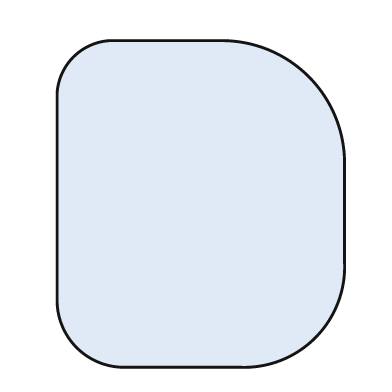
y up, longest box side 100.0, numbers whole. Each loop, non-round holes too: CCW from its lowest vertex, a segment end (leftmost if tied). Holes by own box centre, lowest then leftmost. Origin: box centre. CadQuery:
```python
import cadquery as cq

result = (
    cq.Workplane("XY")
    .moveTo(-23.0, -50.0)
    .lineTo(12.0, -50.0)
    .threePointArc((35.0, -41.0), (44.0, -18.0))
    .lineTo(44.0, 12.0)
    .threePointArc((33.0, 39.0), (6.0, 50.0))
    .lineTo(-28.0, 50.0)
    .threePointArc((-39.0, 45.0), (-44.0, 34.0))
    .lineTo(-44.0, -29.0)
    .threePointArc((-38.0, -44.0), (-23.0, -50.0))
    .close()
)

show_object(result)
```